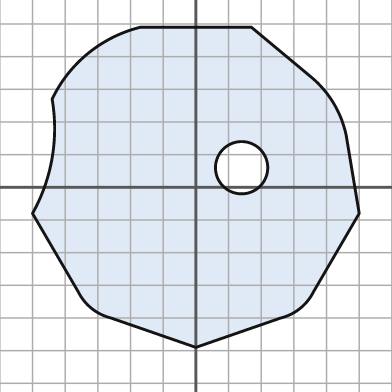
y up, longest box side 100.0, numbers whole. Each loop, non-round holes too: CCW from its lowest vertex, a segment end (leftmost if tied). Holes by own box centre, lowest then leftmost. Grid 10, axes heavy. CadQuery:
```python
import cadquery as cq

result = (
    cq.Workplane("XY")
    .moveTo(0.0, -49.0)
    .lineTo(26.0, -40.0)
    .threePointArc((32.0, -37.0), (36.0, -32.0))
    .lineTo(50.0, -8.0)
    .lineTo(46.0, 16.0)
    .threePointArc((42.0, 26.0), (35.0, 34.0))
    .lineTo(17.0, 49.0)
    .lineTo(-17.0, 49.0)
    .threePointArc((-33.0, 41.0), (-44.0, 27.0))
    .threePointArc((-44.0, 9.0), (-50.0, -8.0))
    .lineTo(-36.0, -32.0)
    .threePointArc((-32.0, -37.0), (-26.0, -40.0))
    .close()
    .moveTo(14.0, 6.0)
    .circle(8.0)
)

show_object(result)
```